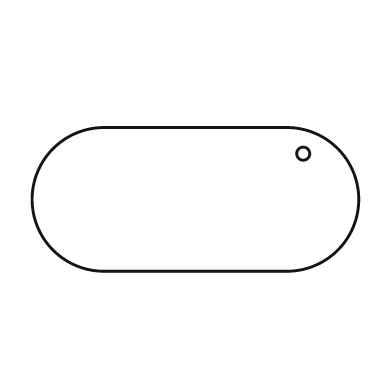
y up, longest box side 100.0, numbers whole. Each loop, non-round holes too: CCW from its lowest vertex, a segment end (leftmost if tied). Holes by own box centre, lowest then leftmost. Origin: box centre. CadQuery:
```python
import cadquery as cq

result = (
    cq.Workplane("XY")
    .moveTo(-28.0, -22.0)
    .lineTo(28.0, -22.0)
    .threePointArc((50.0, 0.0), (28.0, 22.0))
    .lineTo(-28.0, 22.0)
    .threePointArc((-50.0, 0.0), (-28.0, -22.0))
    .close()
    .moveTo(33.0, 14.0)
    .circle(2.0)
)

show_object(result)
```